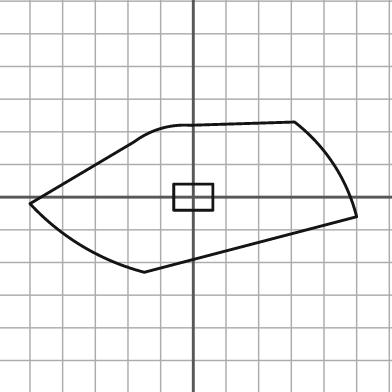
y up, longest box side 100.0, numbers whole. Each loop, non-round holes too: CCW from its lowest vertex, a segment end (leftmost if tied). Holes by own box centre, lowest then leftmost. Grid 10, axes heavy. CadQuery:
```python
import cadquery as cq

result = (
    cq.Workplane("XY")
    .moveTo(-15.0, -23.0)
    .lineTo(50.0, -6.0)
    .threePointArc((43.0, 10.0), (31.0, 23.0))
    .lineTo(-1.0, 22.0)
    .threePointArc((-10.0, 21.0), (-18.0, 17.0))
    .lineTo(-50.0, -2.0)
    .threePointArc((-34.0, -15.0), (-15.0, -23.0))
    .close()
    .moveTo(-6.0, -4.0)
    .lineTo(6.0, -4.0)
    .lineTo(6.0, 4.0)
    .lineTo(-6.0, 4.0)
    .close()
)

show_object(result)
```